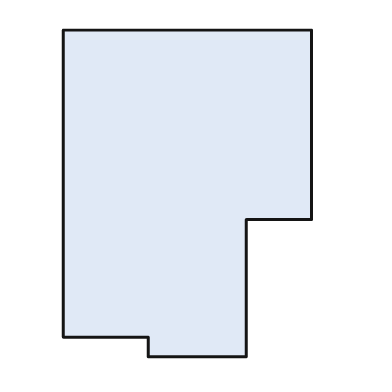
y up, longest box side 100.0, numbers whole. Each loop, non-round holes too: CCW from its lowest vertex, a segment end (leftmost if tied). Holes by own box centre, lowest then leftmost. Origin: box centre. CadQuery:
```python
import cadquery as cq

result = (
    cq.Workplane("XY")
    .moveTo(-12.0, -50.0)
    .lineTo(18.0, -50.0)
    .lineTo(18.0, -8.0)
    .lineTo(38.0, -8.0)
    .lineTo(38.0, 50.0)
    .lineTo(-38.0, 50.0)
    .lineTo(-38.0, -44.0)
    .lineTo(-12.0, -44.0)
    .close()
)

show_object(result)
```